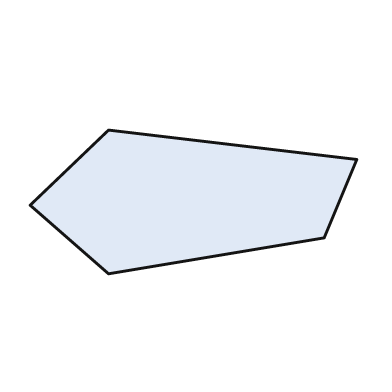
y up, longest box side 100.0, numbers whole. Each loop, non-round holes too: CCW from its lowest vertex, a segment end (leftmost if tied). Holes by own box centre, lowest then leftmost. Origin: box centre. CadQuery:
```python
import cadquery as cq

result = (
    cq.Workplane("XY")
    .moveTo(-26.0, -22.0)
    .lineTo(40.0, -11.0)
    .lineTo(50.0, 13.0)
    .lineTo(-26.0, 22.0)
    .lineTo(-50.0, -1.0)
    .close()
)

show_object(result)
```